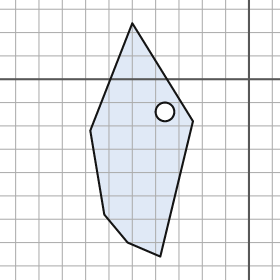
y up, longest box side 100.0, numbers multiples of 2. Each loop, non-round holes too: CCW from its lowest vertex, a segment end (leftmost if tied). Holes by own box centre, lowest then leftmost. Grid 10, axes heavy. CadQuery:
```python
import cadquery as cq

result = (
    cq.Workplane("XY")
    .moveTo(-38.0, -76.0)
    .lineTo(-24.0, -18.0)
    .lineTo(-50.0, 24.0)
    .lineTo(-68.0, -22.0)
    .lineTo(-62.0, -58.0)
    .lineTo(-52.0, -70.0)
    .close()
    .moveTo(-36.0, -14.0)
    .circle(4.0)
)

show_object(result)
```